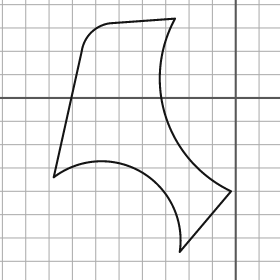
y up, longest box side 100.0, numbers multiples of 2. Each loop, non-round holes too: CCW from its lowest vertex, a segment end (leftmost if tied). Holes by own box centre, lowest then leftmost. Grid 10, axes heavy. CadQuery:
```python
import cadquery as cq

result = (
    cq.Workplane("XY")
    .moveTo(-24.0, -66.0)
    .lineTo(-2.0, -40.0)
    .threePointArc((-30.0, -8.0), (-26.0, 34.0))
    .lineTo(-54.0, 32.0)
    .threePointArc((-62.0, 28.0), (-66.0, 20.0))
    .lineTo(-78.0, -34.0)
    .threePointArc((-40.0, -32.0), (-24.0, -66.0))
    .close()
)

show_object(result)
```